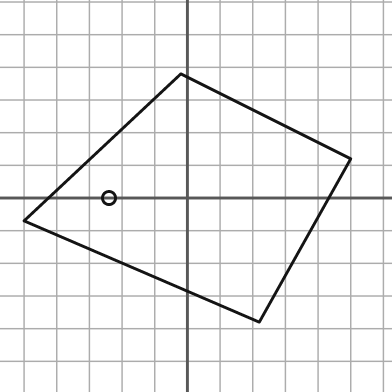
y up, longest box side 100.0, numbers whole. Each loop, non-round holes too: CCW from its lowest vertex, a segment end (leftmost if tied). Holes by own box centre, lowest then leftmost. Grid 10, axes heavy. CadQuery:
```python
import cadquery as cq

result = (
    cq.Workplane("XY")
    .moveTo(22.0, -38.0)
    .lineTo(50.0, 12.0)
    .lineTo(-2.0, 38.0)
    .lineTo(-50.0, -7.0)
    .close()
    .moveTo(-24.0, 0.0)
    .circle(2.0)
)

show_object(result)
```